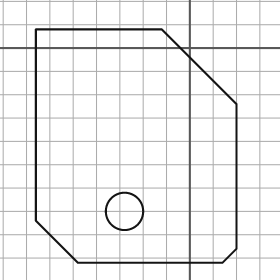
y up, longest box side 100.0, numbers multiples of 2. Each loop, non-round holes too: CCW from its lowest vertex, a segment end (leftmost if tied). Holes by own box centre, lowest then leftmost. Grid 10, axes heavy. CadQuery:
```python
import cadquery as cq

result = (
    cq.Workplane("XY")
    .moveTo(-48.0, -92.0)
    .lineTo(14.0, -92.0)
    .lineTo(20.0, -86.0)
    .lineTo(20.0, -24.0)
    .lineTo(-12.0, 8.0)
    .lineTo(-66.0, 8.0)
    .lineTo(-66.0, -74.0)
    .close()
    .moveTo(-28.0, -70.0)
    .circle(8.0)
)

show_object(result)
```